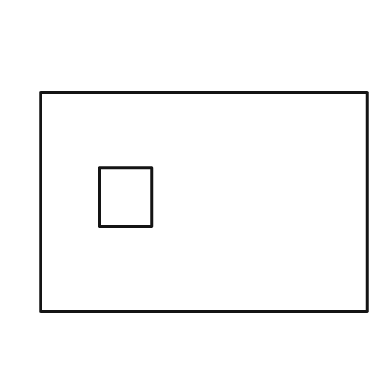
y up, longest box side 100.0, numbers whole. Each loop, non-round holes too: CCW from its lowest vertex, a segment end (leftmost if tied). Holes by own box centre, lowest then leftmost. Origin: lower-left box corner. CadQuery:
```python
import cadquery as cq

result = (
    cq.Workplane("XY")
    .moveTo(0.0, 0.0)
    .lineTo(100.0, 0.0)
    .lineTo(100.0, 67.0)
    .lineTo(0.0, 67.0)
    .close()
    .moveTo(18.0, 26.0)
    .lineTo(34.0, 26.0)
    .lineTo(34.0, 44.0)
    .lineTo(18.0, 44.0)
    .close()
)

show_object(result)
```